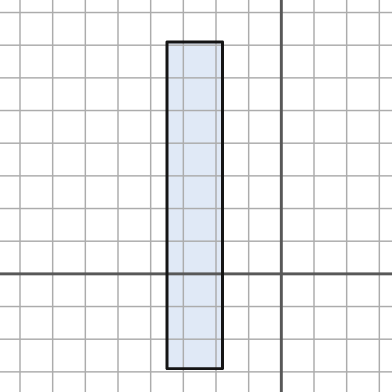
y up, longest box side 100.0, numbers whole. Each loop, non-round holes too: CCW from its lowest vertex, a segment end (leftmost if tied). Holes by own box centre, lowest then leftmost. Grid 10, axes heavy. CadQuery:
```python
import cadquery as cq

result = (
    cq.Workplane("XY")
    .moveTo(-35.0, -29.0)
    .lineTo(-18.0, -29.0)
    .lineTo(-18.0, 71.0)
    .lineTo(-35.0, 71.0)
    .close()
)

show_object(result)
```